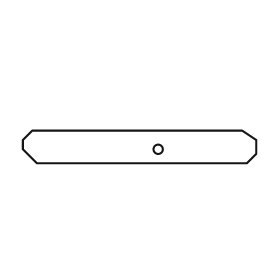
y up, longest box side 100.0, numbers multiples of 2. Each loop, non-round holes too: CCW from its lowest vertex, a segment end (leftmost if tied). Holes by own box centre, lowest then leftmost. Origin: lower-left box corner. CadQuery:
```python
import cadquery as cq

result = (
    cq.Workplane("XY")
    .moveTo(6.0, 0.0)
    .lineTo(96.0, 0.0)
    .lineTo(100.0, 4.0)
    .lineTo(100.0, 10.0)
    .lineTo(94.0, 14.0)
    .lineTo(4.0, 14.0)
    .lineTo(0.0, 10.0)
    .lineTo(0.0, 6.0)
    .close()
    .moveTo(58.0, 6.0)
    .circle(2.0)
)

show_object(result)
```